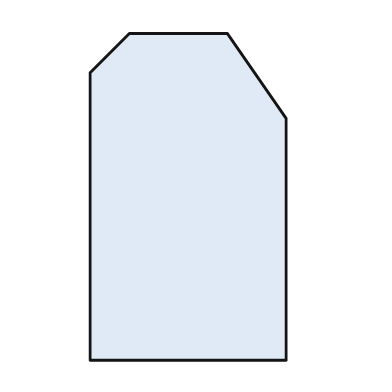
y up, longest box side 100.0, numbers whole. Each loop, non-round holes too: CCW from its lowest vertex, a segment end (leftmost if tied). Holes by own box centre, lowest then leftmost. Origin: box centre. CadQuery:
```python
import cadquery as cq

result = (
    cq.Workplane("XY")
    .moveTo(-30.0, -50.0)
    .lineTo(30.0, -50.0)
    .lineTo(30.0, 24.0)
    .lineTo(12.0, 50.0)
    .lineTo(-18.0, 50.0)
    .lineTo(-30.0, 38.0)
    .close()
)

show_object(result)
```